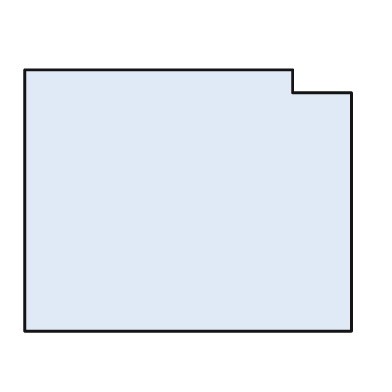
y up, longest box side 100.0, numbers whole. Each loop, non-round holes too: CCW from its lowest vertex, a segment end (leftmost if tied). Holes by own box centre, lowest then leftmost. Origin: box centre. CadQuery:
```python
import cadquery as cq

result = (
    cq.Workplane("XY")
    .moveTo(-50.0, -40.0)
    .lineTo(50.0, -40.0)
    .lineTo(50.0, 33.0)
    .lineTo(32.0, 33.0)
    .lineTo(32.0, 40.0)
    .lineTo(-50.0, 40.0)
    .close()
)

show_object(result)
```